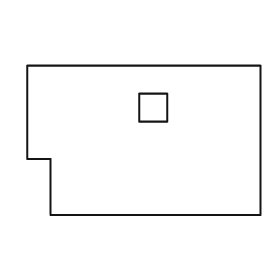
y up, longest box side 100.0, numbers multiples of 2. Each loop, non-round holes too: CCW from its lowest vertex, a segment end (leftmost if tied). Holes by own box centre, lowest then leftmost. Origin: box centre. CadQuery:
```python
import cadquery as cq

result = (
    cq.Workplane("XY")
    .moveTo(-40.0, -32.0)
    .lineTo(50.0, -32.0)
    .lineTo(50.0, 32.0)
    .lineTo(-50.0, 32.0)
    .lineTo(-50.0, -8.0)
    .lineTo(-40.0, -8.0)
    .close()
    .moveTo(-2.0, 8.0)
    .lineTo(10.0, 8.0)
    .lineTo(10.0, 20.0)
    .lineTo(-2.0, 20.0)
    .close()
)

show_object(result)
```